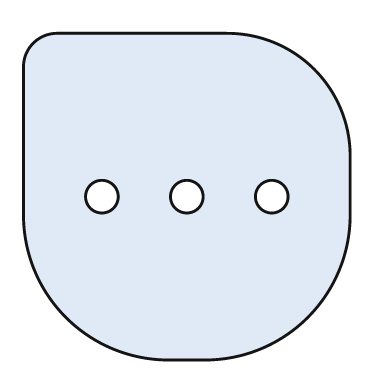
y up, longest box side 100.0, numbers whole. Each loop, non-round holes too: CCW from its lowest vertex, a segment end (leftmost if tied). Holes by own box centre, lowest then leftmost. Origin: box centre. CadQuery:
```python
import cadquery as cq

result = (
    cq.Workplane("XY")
    .moveTo(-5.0, -50.0)
    .lineTo(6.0, -50.0)
    .threePointArc((37.0, -37.0), (50.0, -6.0))
    .lineTo(50.0, 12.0)
    .threePointArc((39.0, 39.0), (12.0, 50.0))
    .lineTo(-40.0, 50.0)
    .threePointArc((-47.0, 47.0), (-50.0, 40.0))
    .lineTo(-50.0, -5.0)
    .threePointArc((-37.0, -37.0), (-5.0, -50.0))
    .close()
    .moveTo(-26.0, 0.0)
    .circle(5.0)
    .moveTo(0.0, 0.0)
    .circle(5.0)
    .moveTo(26.0, 0.0)
    .circle(5.0)
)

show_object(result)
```